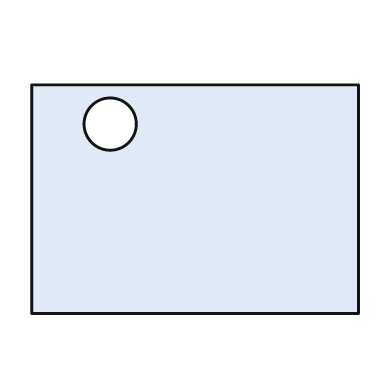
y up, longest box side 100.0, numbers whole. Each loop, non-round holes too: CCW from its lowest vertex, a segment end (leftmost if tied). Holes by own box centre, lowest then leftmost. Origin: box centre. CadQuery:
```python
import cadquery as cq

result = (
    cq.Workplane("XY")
    .moveTo(-50.0, -35.0)
    .lineTo(50.0, -35.0)
    .lineTo(50.0, 35.0)
    .lineTo(-50.0, 35.0)
    .close()
    .moveTo(-26.0, 23.0)
    .circle(8.0)
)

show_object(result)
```